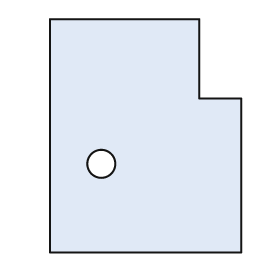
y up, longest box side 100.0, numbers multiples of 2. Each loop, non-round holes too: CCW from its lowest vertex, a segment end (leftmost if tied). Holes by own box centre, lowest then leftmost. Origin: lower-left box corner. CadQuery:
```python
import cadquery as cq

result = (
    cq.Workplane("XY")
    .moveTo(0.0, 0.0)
    .lineTo(82.0, 0.0)
    .lineTo(82.0, 66.0)
    .lineTo(64.0, 66.0)
    .lineTo(64.0, 100.0)
    .lineTo(0.0, 100.0)
    .close()
    .moveTo(22.0, 38.0)
    .circle(6.0)
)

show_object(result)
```